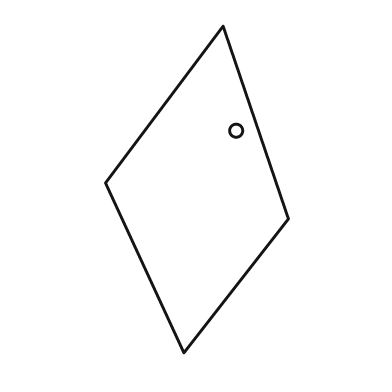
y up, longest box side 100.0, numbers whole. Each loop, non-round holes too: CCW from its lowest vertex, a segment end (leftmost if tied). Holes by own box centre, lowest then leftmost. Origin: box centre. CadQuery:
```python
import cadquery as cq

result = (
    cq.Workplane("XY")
    .moveTo(-4.0, -50.0)
    .lineTo(28.0, -9.0)
    .lineTo(8.0, 50.0)
    .lineTo(-28.0, 2.0)
    .close()
    .moveTo(12.0, 18.0)
    .circle(2.0)
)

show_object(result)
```